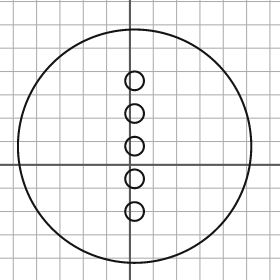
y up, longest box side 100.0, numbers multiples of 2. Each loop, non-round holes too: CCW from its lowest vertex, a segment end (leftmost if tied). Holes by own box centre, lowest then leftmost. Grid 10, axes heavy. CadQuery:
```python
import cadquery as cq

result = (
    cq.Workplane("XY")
    .moveTo(2.0, 8.0)
    .circle(50.0)
    .moveTo(2.0, -20.0)
    .circle(4.0)
    .moveTo(2.0, -6.0)
    .circle(4.0)
    .moveTo(2.0, 8.0)
    .circle(4.0)
    .moveTo(2.0, 22.0)
    .circle(4.0)
    .moveTo(2.0, 36.0)
    .circle(4.0)
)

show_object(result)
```